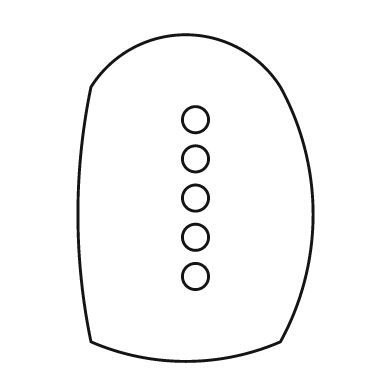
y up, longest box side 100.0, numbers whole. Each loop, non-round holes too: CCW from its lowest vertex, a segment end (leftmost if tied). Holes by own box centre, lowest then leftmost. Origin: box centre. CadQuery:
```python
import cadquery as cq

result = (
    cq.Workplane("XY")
    .moveTo(-32.0, -44.0)
    .threePointArc((-3.0, -50.0), (26.0, -44.0))
    .threePointArc((36.0, -5.0), (26.0, 34.0))
    .threePointArc((-3.0, 50.0), (-32.0, 34.0))
    .threePointArc((-36.0, -5.0), (-32.0, -44.0))
    .close()
    .moveTo(0.0, -24.0)
    .circle(4.0)
    .moveTo(0.0, -12.0)
    .circle(4.0)
    .moveTo(0.0, 0.0)
    .circle(4.0)
    .moveTo(0.0, 12.0)
    .circle(4.0)
    .moveTo(0.0, 24.0)
    .circle(4.0)
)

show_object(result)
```